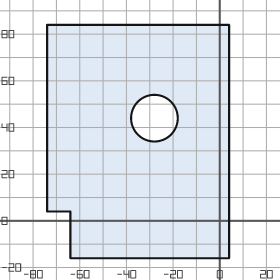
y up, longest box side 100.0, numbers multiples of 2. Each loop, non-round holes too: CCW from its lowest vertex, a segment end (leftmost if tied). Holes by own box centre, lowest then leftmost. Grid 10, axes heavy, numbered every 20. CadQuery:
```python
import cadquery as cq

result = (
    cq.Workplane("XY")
    .moveTo(-64.0, -16.0)
    .lineTo(4.0, -16.0)
    .lineTo(4.0, 84.0)
    .lineTo(-74.0, 84.0)
    .lineTo(-74.0, 4.0)
    .lineTo(-64.0, 4.0)
    .close()
    .moveTo(-28.0, 44.0)
    .circle(10.0)
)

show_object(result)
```